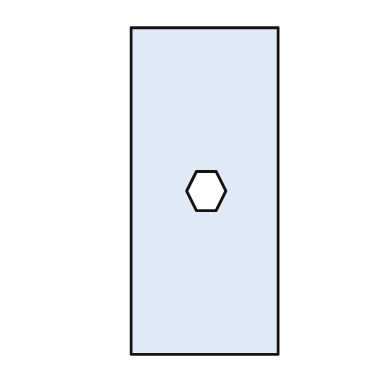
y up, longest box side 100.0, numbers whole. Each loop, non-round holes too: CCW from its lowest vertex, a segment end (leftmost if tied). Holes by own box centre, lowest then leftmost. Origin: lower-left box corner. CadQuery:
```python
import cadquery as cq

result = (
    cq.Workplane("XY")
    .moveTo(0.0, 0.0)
    .lineTo(45.0, 0.0)
    .lineTo(45.0, 100.0)
    .lineTo(0.0, 100.0)
    .close()
    .moveTo(20.0, 44.0)
    .lineTo(26.0, 44.0)
    .lineTo(29.0, 50.0)
    .lineTo(26.0, 56.0)
    .lineTo(20.0, 56.0)
    .lineTo(17.0, 50.0)
    .close()
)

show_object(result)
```